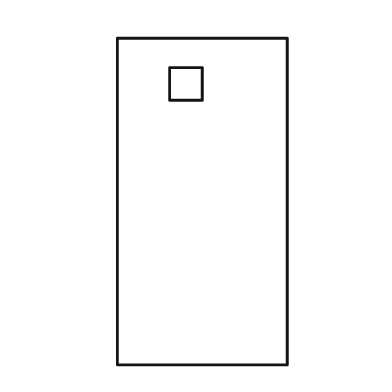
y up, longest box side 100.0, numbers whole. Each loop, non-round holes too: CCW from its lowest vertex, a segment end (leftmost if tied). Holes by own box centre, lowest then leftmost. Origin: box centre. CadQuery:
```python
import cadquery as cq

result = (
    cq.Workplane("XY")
    .moveTo(-26.0, -50.0)
    .lineTo(26.0, -50.0)
    .lineTo(26.0, 50.0)
    .lineTo(-26.0, 50.0)
    .close()
    .moveTo(-10.0, 31.0)
    .lineTo(0.0, 31.0)
    .lineTo(0.0, 41.0)
    .lineTo(-10.0, 41.0)
    .close()
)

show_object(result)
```